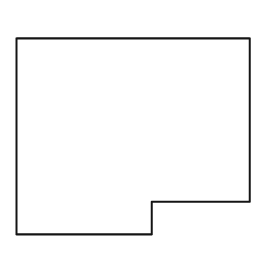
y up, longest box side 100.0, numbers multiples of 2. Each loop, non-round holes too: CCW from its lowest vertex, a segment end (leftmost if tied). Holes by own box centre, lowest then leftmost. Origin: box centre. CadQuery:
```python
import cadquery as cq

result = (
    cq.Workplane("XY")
    .moveTo(-50.0, -42.0)
    .lineTo(8.0, -42.0)
    .lineTo(8.0, -28.0)
    .lineTo(50.0, -28.0)
    .lineTo(50.0, 42.0)
    .lineTo(-50.0, 42.0)
    .close()
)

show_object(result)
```